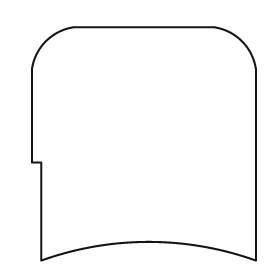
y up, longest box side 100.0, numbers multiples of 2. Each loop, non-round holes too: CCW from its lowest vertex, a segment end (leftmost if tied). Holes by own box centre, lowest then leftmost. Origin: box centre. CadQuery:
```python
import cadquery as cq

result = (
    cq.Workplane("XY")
    .moveTo(-44.0, -50.0)
    .threePointArc((2.0, -42.0), (48.0, -50.0))
    .lineTo(48.0, 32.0)
    .threePointArc((42.0, 44.0), (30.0, 50.0))
    .lineTo(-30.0, 50.0)
    .threePointArc((-42.0, 44.0), (-48.0, 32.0))
    .lineTo(-48.0, -8.0)
    .lineTo(-44.0, -8.0)
    .close()
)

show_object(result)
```